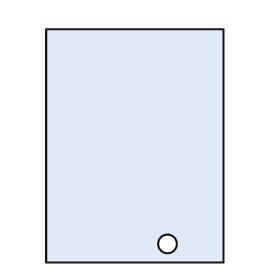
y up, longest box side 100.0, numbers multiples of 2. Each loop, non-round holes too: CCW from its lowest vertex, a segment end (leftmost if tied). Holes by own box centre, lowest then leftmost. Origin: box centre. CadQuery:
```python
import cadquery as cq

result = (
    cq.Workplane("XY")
    .moveTo(-38.0, -50.0)
    .lineTo(38.0, -50.0)
    .lineTo(38.0, 50.0)
    .lineTo(-38.0, 50.0)
    .close()
    .moveTo(14.0, -42.0)
    .circle(4.0)
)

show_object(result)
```